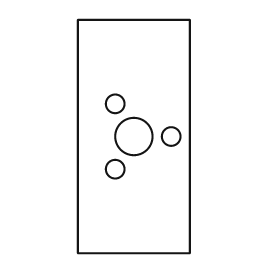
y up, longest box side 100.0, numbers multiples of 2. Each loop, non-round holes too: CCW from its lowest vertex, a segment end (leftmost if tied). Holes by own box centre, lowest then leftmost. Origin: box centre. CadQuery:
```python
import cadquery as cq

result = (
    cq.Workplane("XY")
    .moveTo(-24.0, -50.0)
    .lineTo(24.0, -50.0)
    .lineTo(24.0, 50.0)
    .lineTo(-24.0, 50.0)
    .close()
    .moveTo(-8.0, -14.0)
    .circle(4.0)
    .moveTo(0.0, 0.0)
    .circle(8.0)
    .moveTo(16.0, 0.0)
    .circle(4.0)
    .moveTo(-8.0, 14.0)
    .circle(4.0)
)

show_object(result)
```